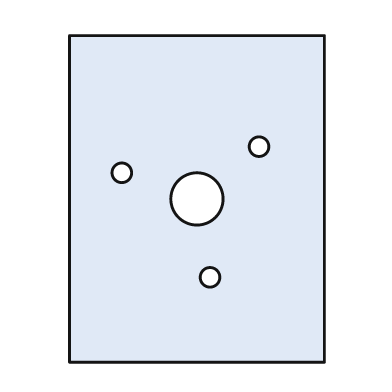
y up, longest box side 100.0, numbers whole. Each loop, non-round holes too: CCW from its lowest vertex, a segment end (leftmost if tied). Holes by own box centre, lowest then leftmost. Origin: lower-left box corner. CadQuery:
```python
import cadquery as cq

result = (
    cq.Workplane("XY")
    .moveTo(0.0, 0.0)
    .lineTo(78.0, 0.0)
    .lineTo(78.0, 100.0)
    .lineTo(0.0, 100.0)
    .close()
    .moveTo(43.0, 26.0)
    .circle(3.0)
    .moveTo(39.0, 50.0)
    .circle(8.0)
    .moveTo(16.0, 58.0)
    .circle(3.0)
    .moveTo(58.0, 66.0)
    .circle(3.0)
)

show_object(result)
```